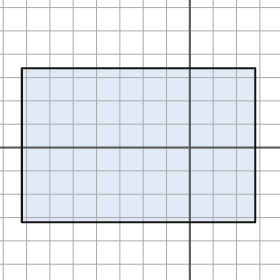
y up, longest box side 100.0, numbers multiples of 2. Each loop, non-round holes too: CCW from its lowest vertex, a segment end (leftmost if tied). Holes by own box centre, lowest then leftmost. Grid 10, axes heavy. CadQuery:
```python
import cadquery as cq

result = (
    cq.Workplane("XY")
    .moveTo(-72.0, -32.0)
    .lineTo(28.0, -32.0)
    .lineTo(28.0, 34.0)
    .lineTo(-72.0, 34.0)
    .close()
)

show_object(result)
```